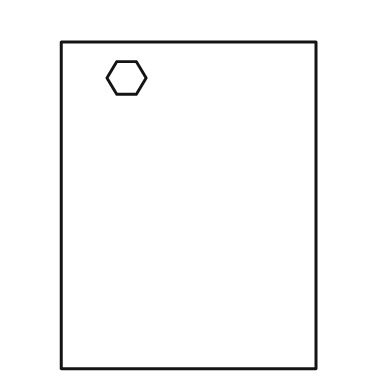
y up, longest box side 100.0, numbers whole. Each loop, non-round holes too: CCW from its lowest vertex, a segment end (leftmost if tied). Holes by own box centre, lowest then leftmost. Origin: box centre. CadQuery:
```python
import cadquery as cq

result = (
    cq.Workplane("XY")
    .moveTo(-39.0, -50.0)
    .lineTo(39.0, -50.0)
    .lineTo(39.0, 50.0)
    .lineTo(-39.0, 50.0)
    .close()
    .moveTo(-22.0, 34.0)
    .lineTo(-16.0, 34.0)
    .lineTo(-13.0, 39.0)
    .lineTo(-16.0, 44.0)
    .lineTo(-22.0, 44.0)
    .lineTo(-25.0, 39.0)
    .close()
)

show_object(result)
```